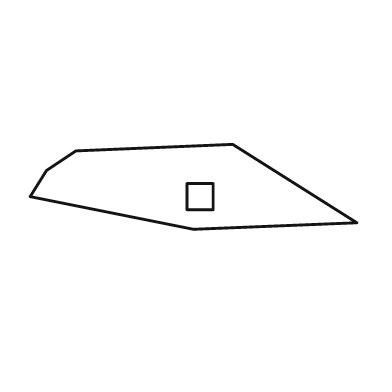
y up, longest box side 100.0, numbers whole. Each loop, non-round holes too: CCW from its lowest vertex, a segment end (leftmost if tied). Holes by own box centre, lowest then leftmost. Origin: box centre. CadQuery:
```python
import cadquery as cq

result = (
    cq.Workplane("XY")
    .moveTo(0.0, -13.0)
    .lineTo(50.0, -11.0)
    .lineTo(12.0, 13.0)
    .lineTo(-36.0, 11.0)
    .lineTo(-45.0, 5.0)
    .lineTo(-50.0, -3.0)
    .close()
    .moveTo(-2.0, -7.0)
    .lineTo(6.0, -7.0)
    .lineTo(6.0, 1.0)
    .lineTo(-2.0, 1.0)
    .close()
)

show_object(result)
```